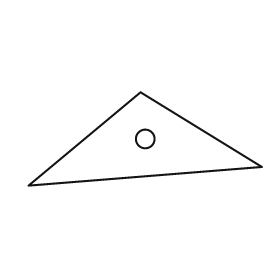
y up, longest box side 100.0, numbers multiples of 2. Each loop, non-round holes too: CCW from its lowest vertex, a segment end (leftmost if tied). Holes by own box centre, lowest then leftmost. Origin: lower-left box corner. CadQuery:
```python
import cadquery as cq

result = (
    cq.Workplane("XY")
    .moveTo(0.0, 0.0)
    .lineTo(100.0, 8.0)
    .lineTo(48.0, 40.0)
    .close()
    .moveTo(50.0, 20.0)
    .circle(4.0)
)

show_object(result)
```